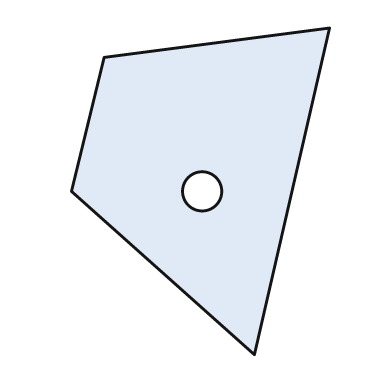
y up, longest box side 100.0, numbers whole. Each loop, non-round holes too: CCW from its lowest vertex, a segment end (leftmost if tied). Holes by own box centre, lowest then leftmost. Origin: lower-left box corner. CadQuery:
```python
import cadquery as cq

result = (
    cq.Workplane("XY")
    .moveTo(56.0, 0.0)
    .lineTo(79.0, 100.0)
    .lineTo(10.0, 91.0)
    .lineTo(0.0, 50.0)
    .close()
    .moveTo(40.0, 50.0)
    .circle(6.0)
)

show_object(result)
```